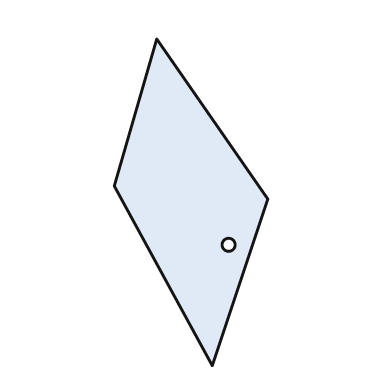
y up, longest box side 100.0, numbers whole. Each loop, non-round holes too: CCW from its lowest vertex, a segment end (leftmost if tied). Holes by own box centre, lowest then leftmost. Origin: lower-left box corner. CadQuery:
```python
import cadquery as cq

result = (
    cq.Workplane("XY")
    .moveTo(30.0, 0.0)
    .lineTo(47.0, 51.0)
    .lineTo(13.0, 100.0)
    .lineTo(0.0, 55.0)
    .close()
    .moveTo(35.0, 37.0)
    .circle(2.0)
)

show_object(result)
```